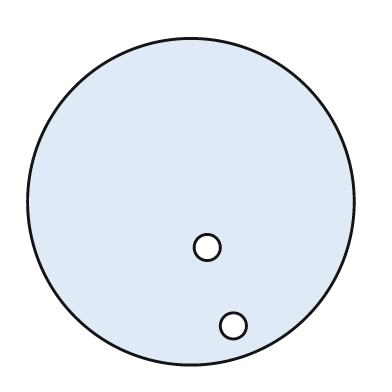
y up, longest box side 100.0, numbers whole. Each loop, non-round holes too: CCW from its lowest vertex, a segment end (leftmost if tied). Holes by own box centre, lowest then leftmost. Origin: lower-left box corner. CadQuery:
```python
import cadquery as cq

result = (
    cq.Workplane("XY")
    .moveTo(50.0, 50.0)
    .circle(50.0)
    .moveTo(63.0, 12.0)
    .circle(4.0)
    .moveTo(55.0, 36.0)
    .circle(4.0)
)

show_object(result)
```